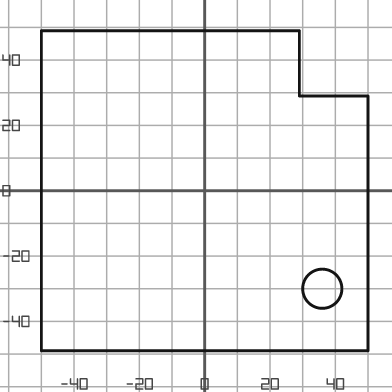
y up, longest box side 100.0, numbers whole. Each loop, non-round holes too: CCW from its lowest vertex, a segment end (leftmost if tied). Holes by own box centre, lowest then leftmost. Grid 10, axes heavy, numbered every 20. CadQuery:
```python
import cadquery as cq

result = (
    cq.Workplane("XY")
    .moveTo(-50.0, -49.0)
    .lineTo(50.0, -49.0)
    .lineTo(50.0, 29.0)
    .lineTo(29.0, 29.0)
    .lineTo(29.0, 49.0)
    .lineTo(-50.0, 49.0)
    .close()
    .moveTo(36.0, -30.0)
    .circle(6.0)
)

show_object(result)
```